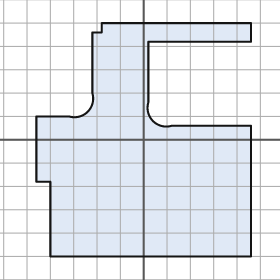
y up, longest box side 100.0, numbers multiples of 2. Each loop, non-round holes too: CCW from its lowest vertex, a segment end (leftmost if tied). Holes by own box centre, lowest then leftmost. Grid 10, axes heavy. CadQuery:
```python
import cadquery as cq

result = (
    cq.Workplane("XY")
    .moveTo(-40.0, -50.0)
    .lineTo(46.0, -50.0)
    .lineTo(46.0, 6.0)
    .lineTo(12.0, 6.0)
    .threePointArc((4.0, 8.0), (2.0, 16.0))
    .lineTo(2.0, 42.0)
    .lineTo(46.0, 42.0)
    .lineTo(46.0, 50.0)
    .lineTo(-18.0, 50.0)
    .lineTo(-18.0, 46.0)
    .lineTo(-22.0, 46.0)
    .lineTo(-22.0, 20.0)
    .threePointArc((-24.0, 12.0), (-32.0, 10.0))
    .lineTo(-46.0, 10.0)
    .lineTo(-46.0, -18.0)
    .lineTo(-40.0, -18.0)
    .close()
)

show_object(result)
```